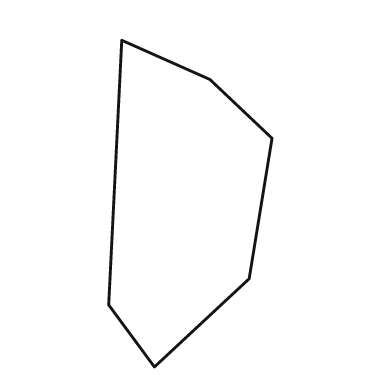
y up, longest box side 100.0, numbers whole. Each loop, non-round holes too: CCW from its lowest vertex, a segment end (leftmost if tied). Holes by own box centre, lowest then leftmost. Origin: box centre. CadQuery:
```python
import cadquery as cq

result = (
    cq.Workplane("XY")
    .moveTo(-11.0, -50.0)
    .lineTo(18.0, -23.0)
    .lineTo(25.0, 20.0)
    .lineTo(6.0, 38.0)
    .lineTo(-21.0, 50.0)
    .lineTo(-25.0, -31.0)
    .close()
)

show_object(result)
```